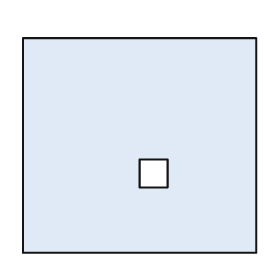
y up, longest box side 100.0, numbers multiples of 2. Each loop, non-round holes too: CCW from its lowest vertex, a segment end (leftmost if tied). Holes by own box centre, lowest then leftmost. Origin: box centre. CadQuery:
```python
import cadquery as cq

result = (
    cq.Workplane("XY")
    .moveTo(-50.0, -46.0)
    .lineTo(50.0, -46.0)
    .lineTo(50.0, 46.0)
    .lineTo(-50.0, 46.0)
    .close()
    .moveTo(0.0, -18.0)
    .lineTo(12.0, -18.0)
    .lineTo(12.0, -6.0)
    .lineTo(0.0, -6.0)
    .close()
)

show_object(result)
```